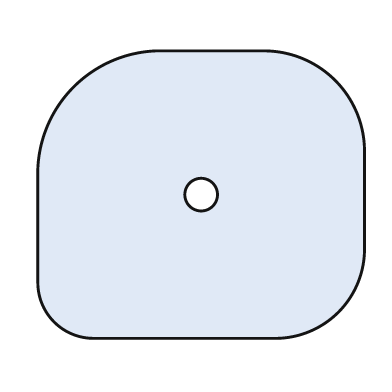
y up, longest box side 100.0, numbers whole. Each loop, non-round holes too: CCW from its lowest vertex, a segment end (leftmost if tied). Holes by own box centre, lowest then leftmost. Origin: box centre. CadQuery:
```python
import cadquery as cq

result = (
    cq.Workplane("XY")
    .moveTo(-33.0, -44.0)
    .lineTo(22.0, -44.0)
    .threePointArc((42.0, -36.0), (50.0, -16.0))
    .lineTo(50.0, 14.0)
    .threePointArc((41.0, 35.0), (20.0, 44.0))
    .lineTo(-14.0, 44.0)
    .threePointArc((-39.0, 33.0), (-50.0, 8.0))
    .lineTo(-50.0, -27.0)
    .threePointArc((-45.0, -39.0), (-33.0, -44.0))
    .close()
    .moveTo(0.0, 0.0)
    .circle(5.0)
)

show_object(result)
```